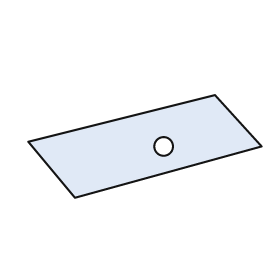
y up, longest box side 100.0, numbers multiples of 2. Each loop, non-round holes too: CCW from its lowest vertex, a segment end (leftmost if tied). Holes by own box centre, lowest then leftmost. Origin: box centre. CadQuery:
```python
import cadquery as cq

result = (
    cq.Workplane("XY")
    .moveTo(-30.0, -22.0)
    .lineTo(50.0, 0.0)
    .lineTo(30.0, 22.0)
    .lineTo(-50.0, 2.0)
    .close()
    .moveTo(8.0, 0.0)
    .circle(4.0)
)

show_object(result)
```